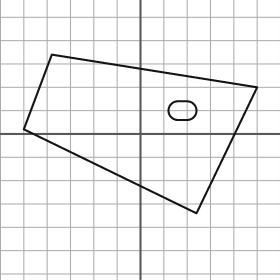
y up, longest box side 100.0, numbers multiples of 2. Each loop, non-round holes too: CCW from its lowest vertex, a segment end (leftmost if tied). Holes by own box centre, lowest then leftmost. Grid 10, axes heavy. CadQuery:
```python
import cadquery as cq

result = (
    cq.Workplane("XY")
    .moveTo(24.0, -34.0)
    .lineTo(50.0, 20.0)
    .lineTo(-38.0, 34.0)
    .lineTo(-50.0, 2.0)
    .close()
    .moveTo(16.0, 6.0)
    .lineTo(20.0, 6.0)
    .threePointArc((24.0, 10.0), (20.0, 14.0))
    .lineTo(16.0, 14.0)
    .threePointArc((12.0, 10.0), (16.0, 6.0))
    .close()
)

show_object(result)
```